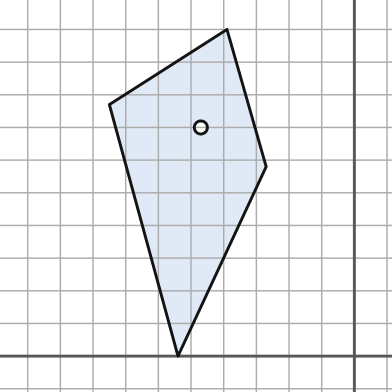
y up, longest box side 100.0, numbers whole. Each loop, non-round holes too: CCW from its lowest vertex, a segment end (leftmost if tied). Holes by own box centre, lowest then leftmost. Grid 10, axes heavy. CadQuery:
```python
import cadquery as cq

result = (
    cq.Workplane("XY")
    .moveTo(-54.0, 0.0)
    .lineTo(-27.0, 58.0)
    .lineTo(-39.0, 100.0)
    .lineTo(-75.0, 77.0)
    .close()
    .moveTo(-47.0, 70.0)
    .circle(2.0)
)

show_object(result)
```